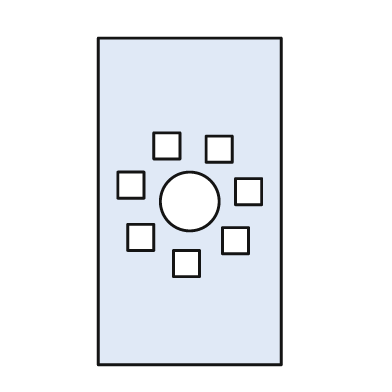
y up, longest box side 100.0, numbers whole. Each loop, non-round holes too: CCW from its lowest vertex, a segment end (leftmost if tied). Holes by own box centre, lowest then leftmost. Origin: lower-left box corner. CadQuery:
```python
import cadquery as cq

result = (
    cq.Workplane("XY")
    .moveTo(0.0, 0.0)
    .lineTo(56.0, 0.0)
    .lineTo(56.0, 100.0)
    .lineTo(0.0, 100.0)
    .close()
    .moveTo(23.0, 27.0)
    .lineTo(31.0, 27.0)
    .lineTo(31.0, 35.0)
    .lineTo(23.0, 35.0)
    .close()
    .moveTo(38.0, 34.0)
    .lineTo(46.0, 34.0)
    .lineTo(46.0, 42.0)
    .lineTo(38.0, 42.0)
    .close()
    .moveTo(9.0, 35.0)
    .lineTo(17.0, 35.0)
    .lineTo(17.0, 43.0)
    .lineTo(9.0, 43.0)
    .close()
    .moveTo(28.0, 50.0)
    .circle(9.0)
    .moveTo(42.0, 49.0)
    .lineTo(50.0, 49.0)
    .lineTo(50.0, 57.0)
    .lineTo(42.0, 57.0)
    .close()
    .moveTo(6.0, 51.0)
    .lineTo(14.0, 51.0)
    .lineTo(14.0, 59.0)
    .lineTo(6.0, 59.0)
    .close()
    .moveTo(33.0, 62.0)
    .lineTo(41.0, 62.0)
    .lineTo(41.0, 70.0)
    .lineTo(33.0, 70.0)
    .close()
    .moveTo(17.0, 63.0)
    .lineTo(25.0, 63.0)
    .lineTo(25.0, 71.0)
    .lineTo(17.0, 71.0)
    .close()
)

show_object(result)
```